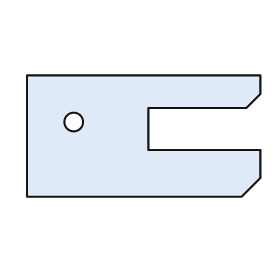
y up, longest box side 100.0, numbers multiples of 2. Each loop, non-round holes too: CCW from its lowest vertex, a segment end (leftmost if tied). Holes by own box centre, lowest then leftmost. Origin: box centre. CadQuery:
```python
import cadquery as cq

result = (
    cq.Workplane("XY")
    .moveTo(-50.0, -26.0)
    .lineTo(42.0, -26.0)
    .lineTo(50.0, -18.0)
    .lineTo(50.0, -6.0)
    .lineTo(2.0, -6.0)
    .lineTo(2.0, 12.0)
    .lineTo(44.0, 12.0)
    .lineTo(50.0, 18.0)
    .lineTo(50.0, 26.0)
    .lineTo(-50.0, 26.0)
    .close()
    .moveTo(-30.0, 6.0)
    .circle(4.0)
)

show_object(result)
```